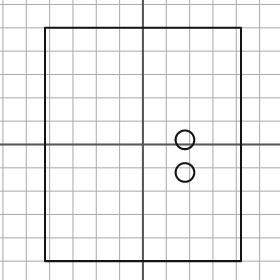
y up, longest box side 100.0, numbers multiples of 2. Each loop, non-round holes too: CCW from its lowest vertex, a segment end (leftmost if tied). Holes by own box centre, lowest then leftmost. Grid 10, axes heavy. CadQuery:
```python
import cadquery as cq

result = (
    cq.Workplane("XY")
    .moveTo(-42.0, -50.0)
    .lineTo(42.0, -50.0)
    .lineTo(42.0, 50.0)
    .lineTo(-42.0, 50.0)
    .close()
    .moveTo(18.0, -12.0)
    .circle(4.0)
    .moveTo(18.0, 2.0)
    .circle(4.0)
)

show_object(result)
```